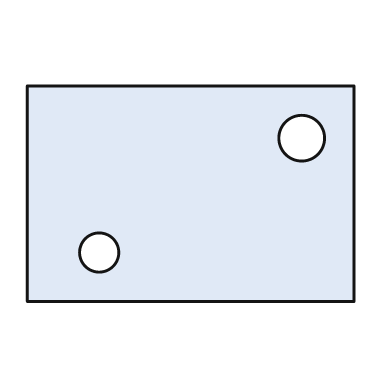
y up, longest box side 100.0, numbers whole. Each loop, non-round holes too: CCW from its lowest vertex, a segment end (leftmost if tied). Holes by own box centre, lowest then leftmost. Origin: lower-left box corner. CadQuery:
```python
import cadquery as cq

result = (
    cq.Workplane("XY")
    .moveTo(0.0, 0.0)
    .lineTo(100.0, 0.0)
    .lineTo(100.0, 66.0)
    .lineTo(0.0, 66.0)
    .close()
    .moveTo(22.0, 15.0)
    .circle(6.0)
    .moveTo(84.0, 50.0)
    .circle(7.0)
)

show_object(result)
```